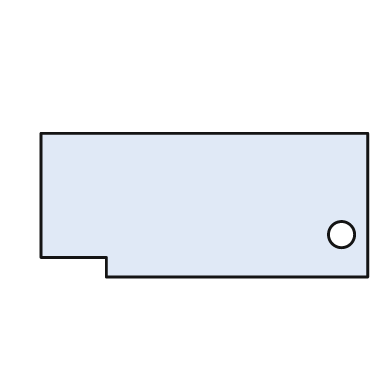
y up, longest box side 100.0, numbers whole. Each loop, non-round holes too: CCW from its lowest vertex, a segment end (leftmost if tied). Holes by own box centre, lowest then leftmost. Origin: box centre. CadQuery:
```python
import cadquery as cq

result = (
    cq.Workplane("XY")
    .moveTo(-30.0, -22.0)
    .lineTo(50.0, -22.0)
    .lineTo(50.0, 22.0)
    .lineTo(-50.0, 22.0)
    .lineTo(-50.0, -16.0)
    .lineTo(-30.0, -16.0)
    .close()
    .moveTo(42.0, -9.0)
    .circle(4.0)
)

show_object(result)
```